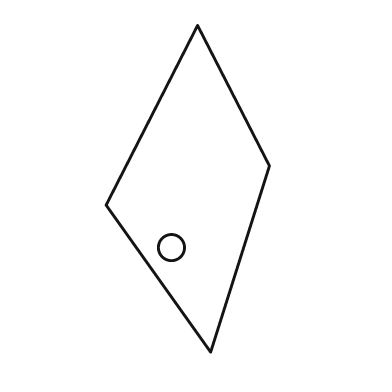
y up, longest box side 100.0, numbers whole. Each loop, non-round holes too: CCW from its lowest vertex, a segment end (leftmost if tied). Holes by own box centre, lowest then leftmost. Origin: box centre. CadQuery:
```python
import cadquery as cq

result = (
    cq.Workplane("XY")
    .moveTo(7.0, -50.0)
    .lineTo(25.0, 7.0)
    .lineTo(3.0, 50.0)
    .lineTo(-25.0, -5.0)
    .close()
    .moveTo(-5.0, -18.0)
    .circle(4.0)
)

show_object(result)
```